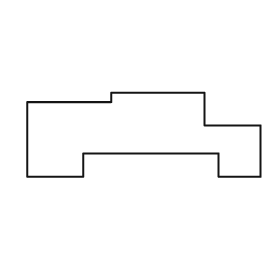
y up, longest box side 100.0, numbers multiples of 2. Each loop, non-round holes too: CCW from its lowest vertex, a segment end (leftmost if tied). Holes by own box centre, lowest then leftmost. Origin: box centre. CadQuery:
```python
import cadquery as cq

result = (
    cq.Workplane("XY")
    .moveTo(-50.0, -18.0)
    .lineTo(-26.0, -18.0)
    .lineTo(-26.0, -8.0)
    .lineTo(32.0, -8.0)
    .lineTo(32.0, -18.0)
    .lineTo(50.0, -18.0)
    .lineTo(50.0, 4.0)
    .lineTo(26.0, 4.0)
    .lineTo(26.0, 18.0)
    .lineTo(-14.0, 18.0)
    .lineTo(-14.0, 14.0)
    .lineTo(-50.0, 14.0)
    .close()
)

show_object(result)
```